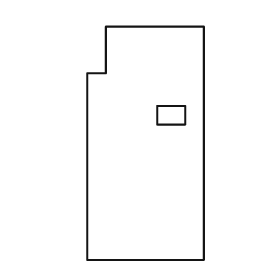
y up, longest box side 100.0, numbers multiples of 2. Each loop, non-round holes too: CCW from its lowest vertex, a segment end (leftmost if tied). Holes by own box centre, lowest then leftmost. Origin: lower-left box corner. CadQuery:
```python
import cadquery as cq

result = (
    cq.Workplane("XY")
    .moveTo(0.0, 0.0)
    .lineTo(50.0, 0.0)
    .lineTo(50.0, 100.0)
    .lineTo(8.0, 100.0)
    .lineTo(8.0, 80.0)
    .lineTo(0.0, 80.0)
    .close()
    .moveTo(30.0, 58.0)
    .lineTo(42.0, 58.0)
    .lineTo(42.0, 66.0)
    .lineTo(30.0, 66.0)
    .close()
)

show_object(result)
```